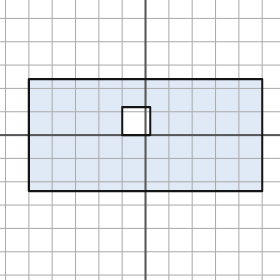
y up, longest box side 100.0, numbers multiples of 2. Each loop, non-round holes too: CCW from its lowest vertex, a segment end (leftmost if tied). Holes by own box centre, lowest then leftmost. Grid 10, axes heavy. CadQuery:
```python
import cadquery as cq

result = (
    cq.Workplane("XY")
    .moveTo(-50.0, -24.0)
    .lineTo(50.0, -24.0)
    .lineTo(50.0, 24.0)
    .lineTo(-50.0, 24.0)
    .close()
    .moveTo(-10.0, 0.0)
    .lineTo(2.0, 0.0)
    .lineTo(2.0, 12.0)
    .lineTo(-10.0, 12.0)
    .close()
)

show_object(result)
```